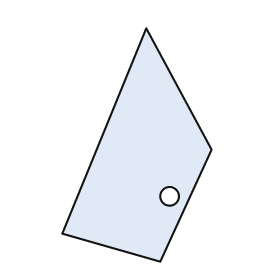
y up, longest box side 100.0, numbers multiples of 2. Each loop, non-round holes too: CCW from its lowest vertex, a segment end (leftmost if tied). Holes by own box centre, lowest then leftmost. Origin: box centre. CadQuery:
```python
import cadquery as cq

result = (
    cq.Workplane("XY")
    .moveTo(10.0, -50.0)
    .lineTo(32.0, -2.0)
    .lineTo(4.0, 50.0)
    .lineTo(-32.0, -38.0)
    .close()
    .moveTo(14.0, -22.0)
    .circle(4.0)
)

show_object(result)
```